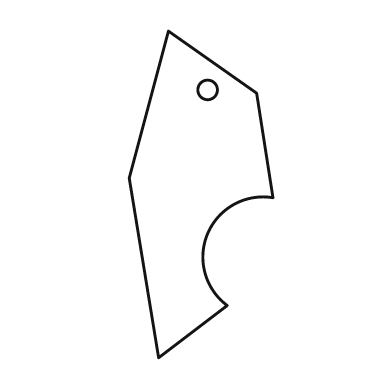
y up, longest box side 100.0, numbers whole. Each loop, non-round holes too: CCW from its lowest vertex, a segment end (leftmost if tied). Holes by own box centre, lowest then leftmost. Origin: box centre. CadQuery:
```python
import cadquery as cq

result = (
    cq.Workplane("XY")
    .moveTo(-13.0, -50.0)
    .lineTo(8.0, -34.0)
    .threePointArc((2.0, -12.0), (22.0, -1.0))
    .lineTo(17.0, 31.0)
    .lineTo(-10.0, 50.0)
    .lineTo(-22.0, 5.0)
    .close()
    .moveTo(2.0, 32.0)
    .circle(3.0)
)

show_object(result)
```